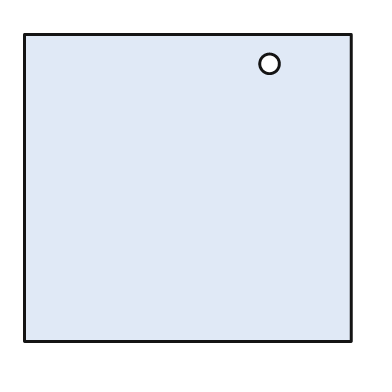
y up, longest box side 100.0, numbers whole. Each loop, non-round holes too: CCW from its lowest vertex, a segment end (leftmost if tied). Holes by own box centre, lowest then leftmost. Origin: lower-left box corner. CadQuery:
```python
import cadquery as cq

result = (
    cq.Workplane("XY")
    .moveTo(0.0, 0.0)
    .lineTo(100.0, 0.0)
    .lineTo(100.0, 94.0)
    .lineTo(0.0, 94.0)
    .close()
    .moveTo(75.0, 85.0)
    .circle(3.0)
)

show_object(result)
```